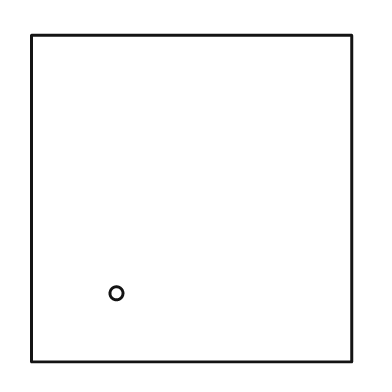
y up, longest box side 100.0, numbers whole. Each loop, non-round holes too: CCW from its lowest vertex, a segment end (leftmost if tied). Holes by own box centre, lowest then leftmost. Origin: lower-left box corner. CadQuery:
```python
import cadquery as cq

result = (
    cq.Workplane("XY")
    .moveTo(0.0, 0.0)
    .lineTo(98.0, 0.0)
    .lineTo(98.0, 100.0)
    .lineTo(0.0, 100.0)
    .close()
    .moveTo(26.0, 21.0)
    .circle(2.0)
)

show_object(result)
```